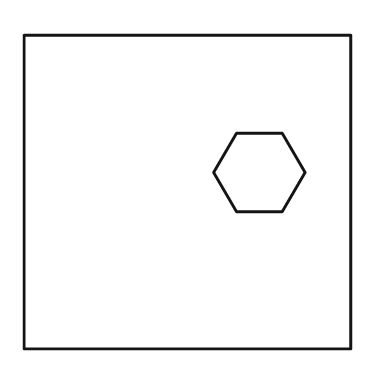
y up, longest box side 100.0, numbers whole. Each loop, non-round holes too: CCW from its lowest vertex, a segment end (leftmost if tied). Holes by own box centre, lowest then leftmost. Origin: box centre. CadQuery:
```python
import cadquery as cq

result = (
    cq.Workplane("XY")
    .moveTo(-50.0, -48.0)
    .lineTo(50.0, -48.0)
    .lineTo(50.0, 48.0)
    .lineTo(-50.0, 48.0)
    .close()
    .moveTo(15.0, -6.0)
    .lineTo(29.0, -6.0)
    .lineTo(36.0, 6.0)
    .lineTo(29.0, 18.0)
    .lineTo(15.0, 18.0)
    .lineTo(8.0, 6.0)
    .close()
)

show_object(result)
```